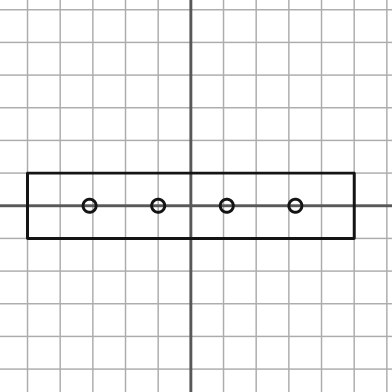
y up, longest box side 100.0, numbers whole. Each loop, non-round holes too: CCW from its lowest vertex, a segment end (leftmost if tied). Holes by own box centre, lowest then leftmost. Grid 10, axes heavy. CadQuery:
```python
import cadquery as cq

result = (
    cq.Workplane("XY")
    .moveTo(-50.0, -10.0)
    .lineTo(50.0, -10.0)
    .lineTo(50.0, 10.0)
    .lineTo(-50.0, 10.0)
    .close()
    .moveTo(-31.0, 0.0)
    .circle(2.0)
    .moveTo(-10.0, 0.0)
    .circle(2.0)
    .moveTo(11.0, 0.0)
    .circle(2.0)
    .moveTo(32.0, 0.0)
    .circle(2.0)
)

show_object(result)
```